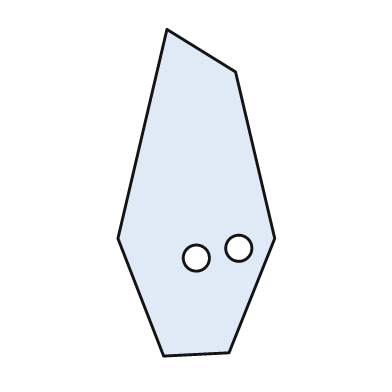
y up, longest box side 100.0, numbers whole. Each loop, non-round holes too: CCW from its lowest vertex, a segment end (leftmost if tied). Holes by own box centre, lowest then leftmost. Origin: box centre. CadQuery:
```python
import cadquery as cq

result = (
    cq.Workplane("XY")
    .moveTo(-10.0, -50.0)
    .lineTo(10.0, -49.0)
    .lineTo(24.0, -14.0)
    .lineTo(12.0, 37.0)
    .lineTo(-9.0, 50.0)
    .lineTo(-24.0, -14.0)
    .close()
    .moveTo(0.0, -20.0)
    .circle(4.0)
    .moveTo(13.0, -17.0)
    .circle(4.0)
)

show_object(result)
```